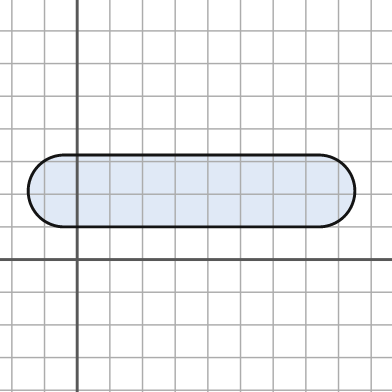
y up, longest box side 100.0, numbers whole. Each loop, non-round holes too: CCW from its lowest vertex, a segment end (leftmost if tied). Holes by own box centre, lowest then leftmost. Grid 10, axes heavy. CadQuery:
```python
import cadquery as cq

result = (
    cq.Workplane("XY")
    .moveTo(-4.0, 10.0)
    .lineTo(74.0, 10.0)
    .threePointArc((85.0, 21.0), (74.0, 32.0))
    .lineTo(-4.0, 32.0)
    .threePointArc((-15.0, 21.0), (-4.0, 10.0))
    .close()
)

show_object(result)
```